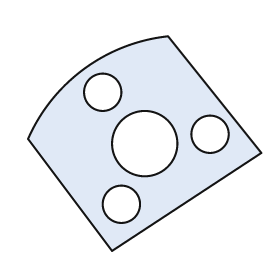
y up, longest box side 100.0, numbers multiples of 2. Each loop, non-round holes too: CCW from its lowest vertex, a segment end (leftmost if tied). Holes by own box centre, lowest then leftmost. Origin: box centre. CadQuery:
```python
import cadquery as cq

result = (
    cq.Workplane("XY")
    .moveTo(-14.0, -46.0)
    .lineTo(50.0, -4.0)
    .lineTo(10.0, 46.0)
    .threePointArc((-26.0, 32.0), (-50.0, 2.0))
    .close()
    .moveTo(-10.0, -26.0)
    .circle(8.0)
    .moveTo(0.0, 0.0)
    .circle(14.0)
    .moveTo(28.0, 4.0)
    .circle(8.0)
    .moveTo(-18.0, 22.0)
    .circle(8.0)
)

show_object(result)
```